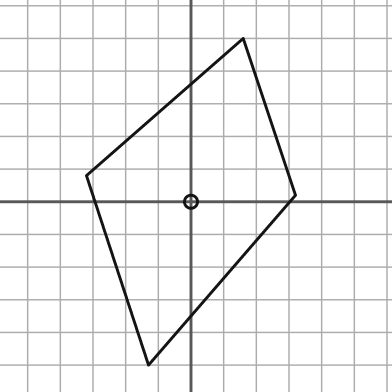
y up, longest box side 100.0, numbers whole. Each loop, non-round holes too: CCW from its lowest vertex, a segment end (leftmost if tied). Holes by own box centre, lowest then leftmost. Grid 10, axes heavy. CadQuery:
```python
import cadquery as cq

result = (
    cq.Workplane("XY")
    .moveTo(-13.0, -50.0)
    .lineTo(32.0, 2.0)
    .lineTo(16.0, 50.0)
    .lineTo(-32.0, 8.0)
    .close()
    .moveTo(0.0, 0.0)
    .circle(2.0)
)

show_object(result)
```